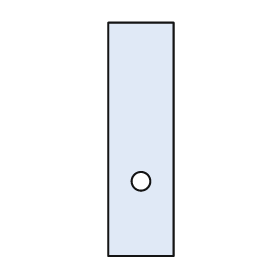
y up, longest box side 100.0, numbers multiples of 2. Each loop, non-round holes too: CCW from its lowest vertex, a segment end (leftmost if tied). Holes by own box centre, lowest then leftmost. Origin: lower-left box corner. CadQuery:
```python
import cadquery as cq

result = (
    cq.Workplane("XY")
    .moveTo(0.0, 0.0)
    .lineTo(28.0, 0.0)
    .lineTo(28.0, 100.0)
    .lineTo(0.0, 100.0)
    .close()
    .moveTo(14.0, 32.0)
    .circle(4.0)
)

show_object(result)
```